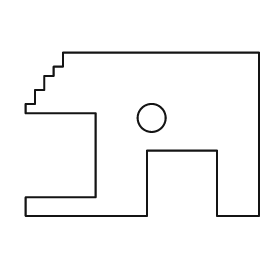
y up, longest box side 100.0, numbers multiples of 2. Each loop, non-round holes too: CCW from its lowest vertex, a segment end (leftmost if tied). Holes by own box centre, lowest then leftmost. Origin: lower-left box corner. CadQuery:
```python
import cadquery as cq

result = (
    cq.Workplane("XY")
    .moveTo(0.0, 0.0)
    .lineTo(52.0, 0.0)
    .lineTo(52.0, 28.0)
    .lineTo(82.0, 28.0)
    .lineTo(82.0, 0.0)
    .lineTo(100.0, 0.0)
    .lineTo(100.0, 70.0)
    .lineTo(16.0, 70.0)
    .lineTo(16.0, 64.0)
    .lineTo(12.0, 64.0)
    .lineTo(12.0, 60.0)
    .lineTo(8.0, 60.0)
    .lineTo(8.0, 54.0)
    .lineTo(4.0, 54.0)
    .lineTo(4.0, 48.0)
    .lineTo(0.0, 48.0)
    .lineTo(0.0, 44.0)
    .lineTo(30.0, 44.0)
    .lineTo(30.0, 8.0)
    .lineTo(0.0, 8.0)
    .close()
    .moveTo(54.0, 42.0)
    .circle(6.0)
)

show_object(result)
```